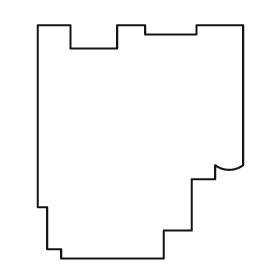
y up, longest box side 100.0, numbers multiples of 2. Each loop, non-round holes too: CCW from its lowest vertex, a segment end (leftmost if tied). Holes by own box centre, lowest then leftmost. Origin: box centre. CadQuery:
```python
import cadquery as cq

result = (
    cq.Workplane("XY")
    .moveTo(-34.0, -50.0)
    .lineTo(10.0, -50.0)
    .lineTo(10.0, -38.0)
    .lineTo(22.0, -38.0)
    .lineTo(22.0, -16.0)
    .lineTo(32.0, -16.0)
    .lineTo(32.0, -10.0)
    .threePointArc((38.0, -12.0), (44.0, -10.0))
    .lineTo(44.0, 50.0)
    .lineTo(24.0, 50.0)
    .lineTo(24.0, 46.0)
    .lineTo(2.0, 46.0)
    .lineTo(2.0, 50.0)
    .lineTo(-10.0, 50.0)
    .lineTo(-10.0, 40.0)
    .lineTo(-30.0, 40.0)
    .lineTo(-30.0, 50.0)
    .lineTo(-44.0, 50.0)
    .lineTo(-44.0, -28.0)
    .lineTo(-40.0, -28.0)
    .lineTo(-40.0, -46.0)
    .lineTo(-34.0, -46.0)
    .close()
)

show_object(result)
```